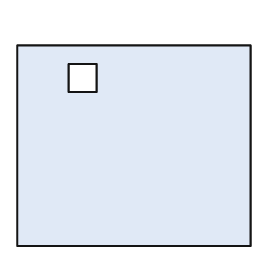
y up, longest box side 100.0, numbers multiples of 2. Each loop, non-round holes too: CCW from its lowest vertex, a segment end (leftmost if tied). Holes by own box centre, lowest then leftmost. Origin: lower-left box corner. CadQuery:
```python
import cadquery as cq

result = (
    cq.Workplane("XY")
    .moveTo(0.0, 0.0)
    .lineTo(100.0, 0.0)
    .lineTo(100.0, 86.0)
    .lineTo(0.0, 86.0)
    .close()
    .moveTo(22.0, 66.0)
    .lineTo(34.0, 66.0)
    .lineTo(34.0, 78.0)
    .lineTo(22.0, 78.0)
    .close()
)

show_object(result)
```